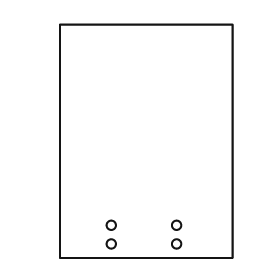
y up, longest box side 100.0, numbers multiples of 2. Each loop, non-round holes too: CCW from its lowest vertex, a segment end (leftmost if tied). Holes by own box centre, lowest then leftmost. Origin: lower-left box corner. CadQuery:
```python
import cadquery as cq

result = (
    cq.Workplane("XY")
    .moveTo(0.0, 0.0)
    .lineTo(74.0, 0.0)
    .lineTo(74.0, 100.0)
    .lineTo(0.0, 100.0)
    .close()
    .moveTo(22.0, 6.0)
    .circle(2.0)
    .moveTo(50.0, 6.0)
    .circle(2.0)
    .moveTo(22.0, 14.0)
    .circle(2.0)
    .moveTo(50.0, 14.0)
    .circle(2.0)
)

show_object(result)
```